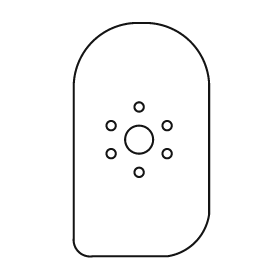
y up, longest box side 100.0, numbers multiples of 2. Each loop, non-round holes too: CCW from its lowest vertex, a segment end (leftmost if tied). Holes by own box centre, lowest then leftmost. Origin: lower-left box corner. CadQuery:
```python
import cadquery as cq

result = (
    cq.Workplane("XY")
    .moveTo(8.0, 0.0)
    .lineTo(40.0, 0.0)
    .threePointArc((52.0, 6.0), (58.0, 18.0))
    .lineTo(58.0, 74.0)
    .threePointArc((50.0, 92.0), (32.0, 100.0))
    .lineTo(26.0, 100.0)
    .threePointArc((8.0, 92.0), (0.0, 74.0))
    .lineTo(0.0, 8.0)
    .threePointArc((2.0, 2.0), (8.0, 0.0))
    .close()
    .moveTo(28.0, 36.0)
    .circle(2.0)
    .moveTo(16.0, 44.0)
    .circle(2.0)
    .moveTo(40.0, 44.0)
    .circle(2.0)
    .moveTo(28.0, 50.0)
    .circle(6.0)
    .moveTo(16.0, 56.0)
    .circle(2.0)
    .moveTo(40.0, 56.0)
    .circle(2.0)
    .moveTo(28.0, 64.0)
    .circle(2.0)
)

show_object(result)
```